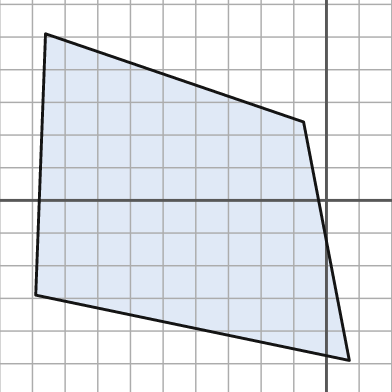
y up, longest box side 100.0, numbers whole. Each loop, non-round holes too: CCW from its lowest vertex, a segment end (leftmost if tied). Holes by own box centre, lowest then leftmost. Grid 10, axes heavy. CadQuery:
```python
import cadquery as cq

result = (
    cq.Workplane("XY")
    .moveTo(7.0, -49.0)
    .lineTo(-7.0, 24.0)
    .lineTo(-86.0, 51.0)
    .lineTo(-89.0, -29.0)
    .close()
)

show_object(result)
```